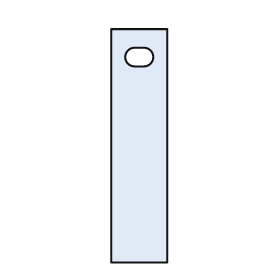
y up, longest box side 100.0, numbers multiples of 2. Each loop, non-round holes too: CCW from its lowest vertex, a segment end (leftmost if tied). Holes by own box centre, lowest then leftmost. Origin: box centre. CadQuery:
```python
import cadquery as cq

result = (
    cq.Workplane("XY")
    .moveTo(-12.0, -50.0)
    .lineTo(12.0, -50.0)
    .lineTo(12.0, 50.0)
    .lineTo(-12.0, 50.0)
    .close()
    .moveTo(-2.0, 34.0)
    .lineTo(2.0, 34.0)
    .threePointArc((6.0, 38.0), (2.0, 42.0))
    .lineTo(-2.0, 42.0)
    .threePointArc((-6.0, 38.0), (-2.0, 34.0))
    .close()
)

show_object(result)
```